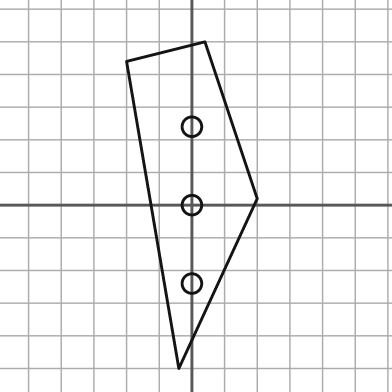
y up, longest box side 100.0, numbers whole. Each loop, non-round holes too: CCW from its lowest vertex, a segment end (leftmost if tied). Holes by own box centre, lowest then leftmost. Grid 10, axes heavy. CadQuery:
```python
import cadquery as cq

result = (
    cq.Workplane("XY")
    .moveTo(-4.0, -50.0)
    .lineTo(20.0, 2.0)
    .lineTo(4.0, 50.0)
    .lineTo(-20.0, 44.0)
    .close()
    .moveTo(0.0, -24.0)
    .circle(3.0)
    .moveTo(0.0, 0.0)
    .circle(3.0)
    .moveTo(0.0, 24.0)
    .circle(3.0)
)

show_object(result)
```